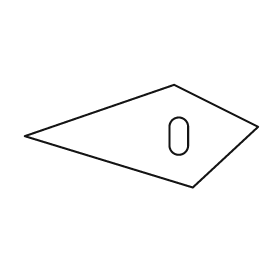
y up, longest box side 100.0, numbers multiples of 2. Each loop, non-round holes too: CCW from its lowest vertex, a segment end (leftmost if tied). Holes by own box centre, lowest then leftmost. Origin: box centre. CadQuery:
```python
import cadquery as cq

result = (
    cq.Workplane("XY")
    .moveTo(22.0, -22.0)
    .lineTo(50.0, 4.0)
    .lineTo(14.0, 22.0)
    .lineTo(-50.0, 0.0)
    .close()
    .moveTo(12.0, -4.0)
    .threePointArc((16.0, -8.0), (20.0, -4.0))
    .lineTo(20.0, 4.0)
    .threePointArc((16.0, 8.0), (12.0, 4.0))
    .close()
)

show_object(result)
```